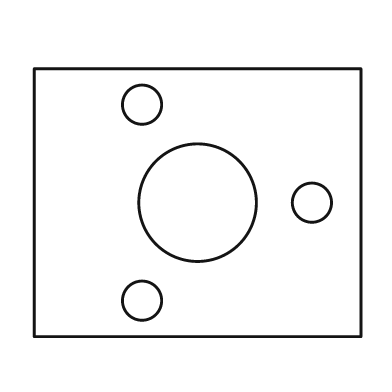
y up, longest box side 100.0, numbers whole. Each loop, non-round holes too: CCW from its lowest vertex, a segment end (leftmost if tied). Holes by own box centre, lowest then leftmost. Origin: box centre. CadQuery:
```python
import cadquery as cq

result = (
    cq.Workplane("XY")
    .moveTo(-50.0, -41.0)
    .lineTo(50.0, -41.0)
    .lineTo(50.0, 41.0)
    .lineTo(-50.0, 41.0)
    .close()
    .moveTo(-17.0, -30.0)
    .circle(6.0)
    .moveTo(0.0, 0.0)
    .circle(18.0)
    .moveTo(35.0, 0.0)
    .circle(6.0)
    .moveTo(-17.0, 30.0)
    .circle(6.0)
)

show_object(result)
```